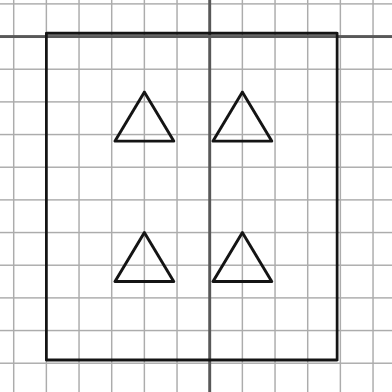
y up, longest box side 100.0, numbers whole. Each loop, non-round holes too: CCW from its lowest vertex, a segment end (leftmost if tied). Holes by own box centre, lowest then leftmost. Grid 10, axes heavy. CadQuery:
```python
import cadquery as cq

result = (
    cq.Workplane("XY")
    .moveTo(-50.0, -99.0)
    .lineTo(39.0, -99.0)
    .lineTo(39.0, 1.0)
    .lineTo(-50.0, 1.0)
    .close()
    .moveTo(-29.0, -75.0)
    .lineTo(-11.0, -75.0)
    .lineTo(-20.0, -60.0)
    .close()
    .moveTo(1.0, -75.0)
    .lineTo(19.0, -75.0)
    .lineTo(10.0, -60.0)
    .close()
    .moveTo(-29.0, -32.0)
    .lineTo(-11.0, -32.0)
    .lineTo(-20.0, -17.0)
    .close()
    .moveTo(1.0, -32.0)
    .lineTo(19.0, -32.0)
    .lineTo(10.0, -17.0)
    .close()
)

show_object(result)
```